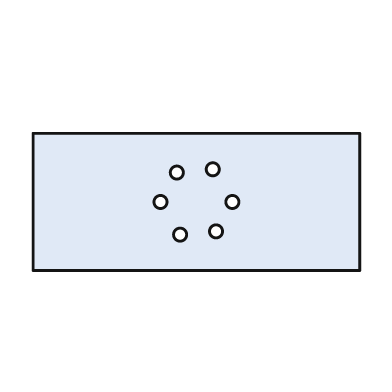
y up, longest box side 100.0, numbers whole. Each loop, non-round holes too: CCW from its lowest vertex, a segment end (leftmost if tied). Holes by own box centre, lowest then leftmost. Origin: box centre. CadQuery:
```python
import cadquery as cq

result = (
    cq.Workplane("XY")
    .moveTo(-50.0, -21.0)
    .lineTo(50.0, -21.0)
    .lineTo(50.0, 21.0)
    .lineTo(-50.0, 21.0)
    .close()
    .moveTo(-5.0, -10.0)
    .circle(2.0)
    .moveTo(6.0, -9.0)
    .circle(2.0)
    .moveTo(-11.0, 0.0)
    .circle(2.0)
    .moveTo(11.0, 0.0)
    .circle(2.0)
    .moveTo(-6.0, 9.0)
    .circle(2.0)
    .moveTo(5.0, 10.0)
    .circle(2.0)
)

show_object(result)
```